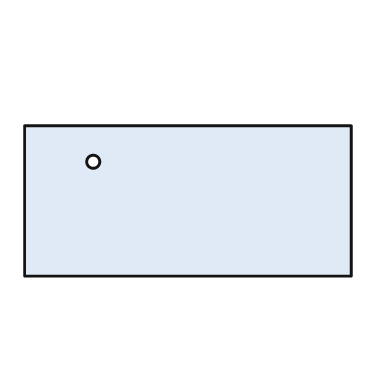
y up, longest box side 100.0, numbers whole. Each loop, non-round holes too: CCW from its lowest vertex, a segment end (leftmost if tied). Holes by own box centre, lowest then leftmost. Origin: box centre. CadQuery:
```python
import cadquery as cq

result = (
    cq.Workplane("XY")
    .moveTo(-50.0, -23.0)
    .lineTo(50.0, -23.0)
    .lineTo(50.0, 23.0)
    .lineTo(-50.0, 23.0)
    .close()
    .moveTo(-29.0, 12.0)
    .circle(2.0)
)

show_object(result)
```